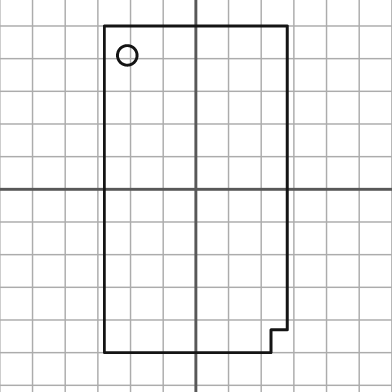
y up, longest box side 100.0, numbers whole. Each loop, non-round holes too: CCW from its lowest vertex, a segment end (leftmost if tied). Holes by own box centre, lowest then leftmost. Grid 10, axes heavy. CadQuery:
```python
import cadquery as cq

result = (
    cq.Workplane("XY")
    .moveTo(-28.0, -50.0)
    .lineTo(23.0, -50.0)
    .lineTo(23.0, -43.0)
    .lineTo(28.0, -43.0)
    .lineTo(28.0, 50.0)
    .lineTo(-28.0, 50.0)
    .close()
    .moveTo(-21.0, 41.0)
    .circle(3.0)
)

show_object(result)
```